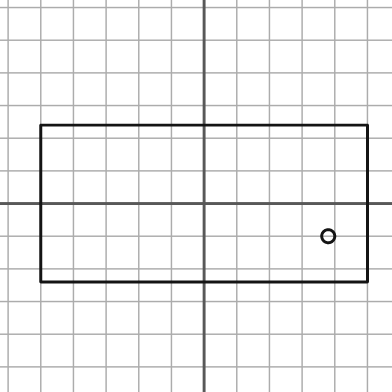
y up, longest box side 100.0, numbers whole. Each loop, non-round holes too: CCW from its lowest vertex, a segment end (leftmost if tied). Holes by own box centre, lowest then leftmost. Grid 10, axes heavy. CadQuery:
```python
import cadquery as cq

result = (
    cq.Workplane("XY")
    .moveTo(-50.0, -24.0)
    .lineTo(50.0, -24.0)
    .lineTo(50.0, 24.0)
    .lineTo(-50.0, 24.0)
    .close()
    .moveTo(38.0, -10.0)
    .circle(2.0)
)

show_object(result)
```